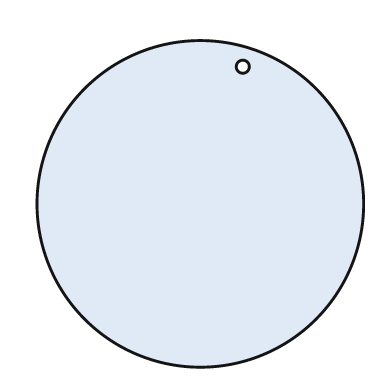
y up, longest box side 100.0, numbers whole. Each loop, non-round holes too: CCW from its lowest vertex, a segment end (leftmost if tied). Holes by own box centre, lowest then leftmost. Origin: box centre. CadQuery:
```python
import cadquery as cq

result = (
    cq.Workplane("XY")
    .moveTo(0.0, 0.0)
    .circle(50.0)
    .moveTo(13.0, 42.0)
    .circle(2.0)
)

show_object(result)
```